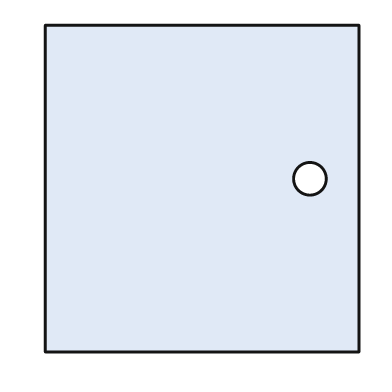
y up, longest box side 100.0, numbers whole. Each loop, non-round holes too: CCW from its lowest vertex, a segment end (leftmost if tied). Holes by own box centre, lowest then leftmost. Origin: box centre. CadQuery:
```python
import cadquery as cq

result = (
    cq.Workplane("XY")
    .moveTo(-48.0, -50.0)
    .lineTo(48.0, -50.0)
    .lineTo(48.0, 50.0)
    .lineTo(-48.0, 50.0)
    .close()
    .moveTo(33.0, 3.0)
    .circle(5.0)
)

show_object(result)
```